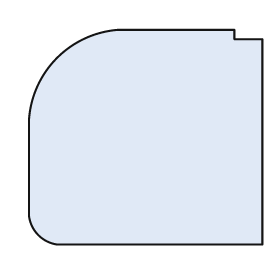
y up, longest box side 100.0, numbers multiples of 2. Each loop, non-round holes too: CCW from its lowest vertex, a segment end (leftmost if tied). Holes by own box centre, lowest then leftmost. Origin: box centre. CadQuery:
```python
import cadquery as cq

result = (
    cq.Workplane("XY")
    .moveTo(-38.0, -46.0)
    .lineTo(50.0, -46.0)
    .lineTo(50.0, 42.0)
    .lineTo(38.0, 42.0)
    .lineTo(38.0, 46.0)
    .lineTo(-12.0, 46.0)
    .threePointArc((-38.0, 34.0), (-50.0, 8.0))
    .lineTo(-50.0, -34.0)
    .threePointArc((-46.0, -42.0), (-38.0, -46.0))
    .close()
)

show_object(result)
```